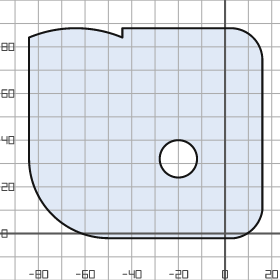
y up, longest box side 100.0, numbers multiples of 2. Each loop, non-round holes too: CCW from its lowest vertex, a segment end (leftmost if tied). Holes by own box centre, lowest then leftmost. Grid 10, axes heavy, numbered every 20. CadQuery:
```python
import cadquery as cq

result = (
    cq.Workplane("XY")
    .moveTo(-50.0, -2.0)
    .lineTo(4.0, -2.0)
    .threePointArc((12.0, 2.0), (16.0, 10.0))
    .lineTo(16.0, 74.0)
    .threePointArc((12.0, 84.0), (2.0, 88.0))
    .lineTo(-44.0, 88.0)
    .lineTo(-44.0, 84.0)
    .threePointArc((-64.0, 88.0), (-84.0, 84.0))
    .lineTo(-84.0, 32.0)
    .threePointArc((-74.0, 8.0), (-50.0, -2.0))
    .close()
    .moveTo(-20.0, 32.0)
    .circle(8.0)
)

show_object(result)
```